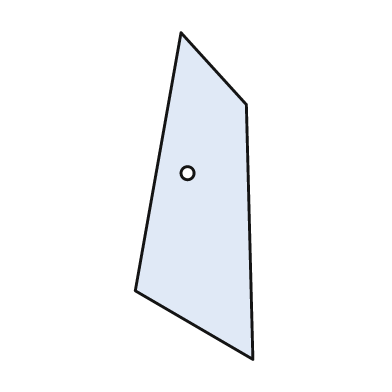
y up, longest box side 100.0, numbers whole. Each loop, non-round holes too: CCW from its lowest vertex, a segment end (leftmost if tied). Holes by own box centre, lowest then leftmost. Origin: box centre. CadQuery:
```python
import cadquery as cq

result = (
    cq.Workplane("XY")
    .moveTo(18.0, -50.0)
    .lineTo(16.0, 28.0)
    .lineTo(-4.0, 50.0)
    .lineTo(-18.0, -29.0)
    .close()
    .moveTo(-2.0, 7.0)
    .circle(2.0)
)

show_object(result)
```